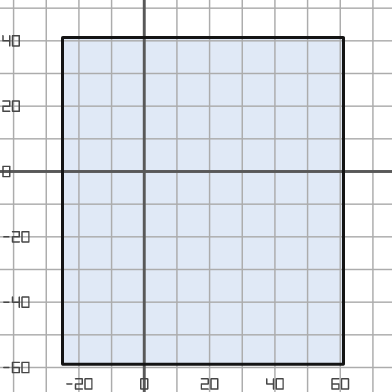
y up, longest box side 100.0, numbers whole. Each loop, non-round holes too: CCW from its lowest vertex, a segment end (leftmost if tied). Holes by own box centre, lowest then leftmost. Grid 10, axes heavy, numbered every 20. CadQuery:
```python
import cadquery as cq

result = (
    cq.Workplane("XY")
    .moveTo(-25.0, -59.0)
    .lineTo(61.0, -59.0)
    .lineTo(61.0, 41.0)
    .lineTo(-25.0, 41.0)
    .close()
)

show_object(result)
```